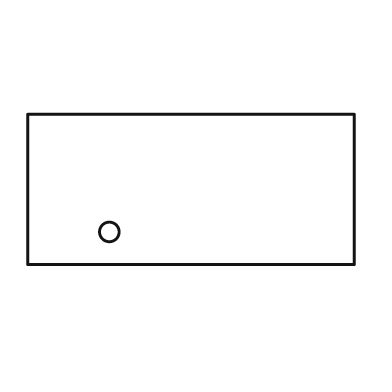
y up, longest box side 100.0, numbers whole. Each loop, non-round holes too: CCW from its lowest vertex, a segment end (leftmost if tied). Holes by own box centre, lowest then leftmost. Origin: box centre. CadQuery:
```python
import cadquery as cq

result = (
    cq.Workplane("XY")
    .moveTo(-50.0, -23.0)
    .lineTo(50.0, -23.0)
    .lineTo(50.0, 23.0)
    .lineTo(-50.0, 23.0)
    .close()
    .moveTo(-25.0, -13.0)
    .circle(3.0)
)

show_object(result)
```